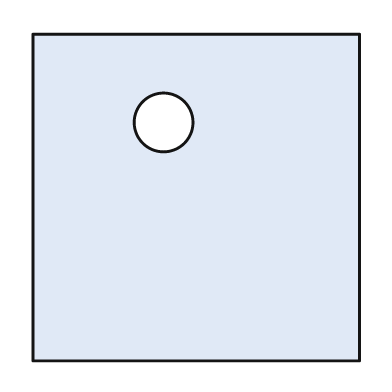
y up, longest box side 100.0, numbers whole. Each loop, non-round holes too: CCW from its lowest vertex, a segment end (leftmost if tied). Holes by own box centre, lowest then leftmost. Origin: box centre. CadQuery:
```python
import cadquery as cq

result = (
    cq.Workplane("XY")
    .moveTo(-50.0, -50.0)
    .lineTo(50.0, -50.0)
    .lineTo(50.0, 50.0)
    .lineTo(-50.0, 50.0)
    .close()
    .moveTo(-10.0, 23.0)
    .circle(9.0)
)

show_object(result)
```